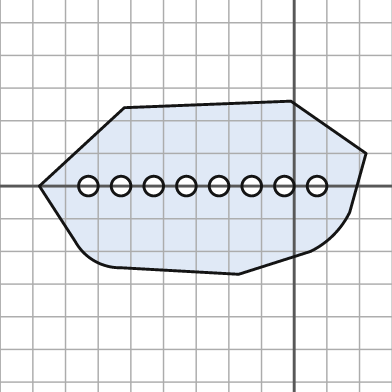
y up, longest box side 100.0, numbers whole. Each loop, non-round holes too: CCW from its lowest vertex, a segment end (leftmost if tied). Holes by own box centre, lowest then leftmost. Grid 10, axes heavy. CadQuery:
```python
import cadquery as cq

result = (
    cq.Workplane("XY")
    .moveTo(-17.0, -27.0)
    .lineTo(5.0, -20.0)
    .threePointArc((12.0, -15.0), (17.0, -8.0))
    .lineTo(22.0, 10.0)
    .lineTo(-1.0, 26.0)
    .lineTo(-52.0, 24.0)
    .lineTo(-78.0, 0.0)
    .lineTo(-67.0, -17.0)
    .threePointArc((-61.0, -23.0), (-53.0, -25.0))
    .close()
    .moveTo(-63.0, 0.0)
    .circle(3.0)
    .moveTo(-53.0, 0.0)
    .circle(3.0)
    .moveTo(-43.0, 0.0)
    .circle(3.0)
    .moveTo(-33.0, 0.0)
    .circle(3.0)
    .moveTo(-23.0, 0.0)
    .circle(3.0)
    .moveTo(-13.0, 0.0)
    .circle(3.0)
    .moveTo(-3.0, 0.0)
    .circle(3.0)
    .moveTo(7.0, 0.0)
    .circle(3.0)
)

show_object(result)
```